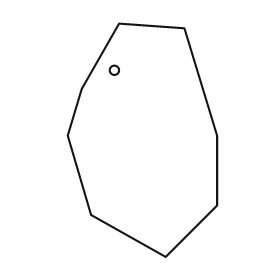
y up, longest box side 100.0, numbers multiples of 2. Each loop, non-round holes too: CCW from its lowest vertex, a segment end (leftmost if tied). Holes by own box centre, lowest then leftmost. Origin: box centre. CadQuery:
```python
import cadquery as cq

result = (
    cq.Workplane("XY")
    .moveTo(10.0, -50.0)
    .lineTo(32.0, -28.0)
    .lineTo(32.0, 2.0)
    .lineTo(18.0, 48.0)
    .lineTo(-10.0, 50.0)
    .lineTo(-26.0, 22.0)
    .lineTo(-32.0, 2.0)
    .lineTo(-22.0, -32.0)
    .close()
    .moveTo(-12.0, 30.0)
    .circle(2.0)
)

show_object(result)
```